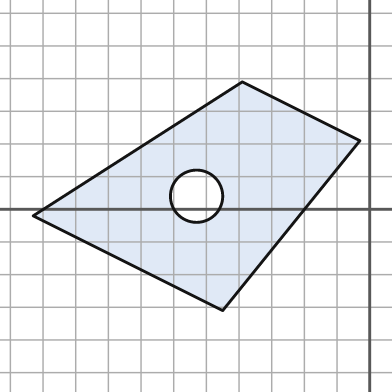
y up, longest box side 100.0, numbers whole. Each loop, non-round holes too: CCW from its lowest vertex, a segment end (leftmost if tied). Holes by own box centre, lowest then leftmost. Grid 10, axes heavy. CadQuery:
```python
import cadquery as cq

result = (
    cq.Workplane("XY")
    .moveTo(-45.0, -31.0)
    .lineTo(-3.0, 21.0)
    .lineTo(-39.0, 39.0)
    .lineTo(-103.0, -2.0)
    .close()
    .moveTo(-53.0, 4.0)
    .circle(8.0)
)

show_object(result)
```